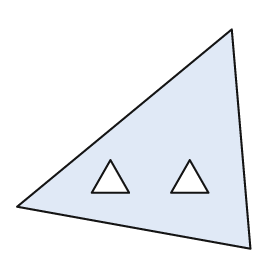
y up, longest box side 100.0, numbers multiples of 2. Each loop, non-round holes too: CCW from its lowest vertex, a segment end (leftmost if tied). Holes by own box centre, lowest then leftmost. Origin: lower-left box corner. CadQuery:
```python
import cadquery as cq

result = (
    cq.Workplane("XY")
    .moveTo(100.0, 0.0)
    .lineTo(92.0, 94.0)
    .lineTo(0.0, 18.0)
    .close()
    .moveTo(32.0, 24.0)
    .lineTo(48.0, 24.0)
    .lineTo(40.0, 38.0)
    .close()
    .moveTo(66.0, 24.0)
    .lineTo(82.0, 24.0)
    .lineTo(74.0, 38.0)
    .close()
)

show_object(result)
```